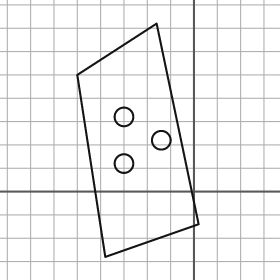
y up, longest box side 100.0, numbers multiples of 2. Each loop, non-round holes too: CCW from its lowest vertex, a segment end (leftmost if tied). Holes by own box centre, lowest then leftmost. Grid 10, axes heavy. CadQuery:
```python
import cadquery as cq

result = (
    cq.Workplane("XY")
    .moveTo(-38.0, -28.0)
    .lineTo(2.0, -14.0)
    .lineTo(-16.0, 72.0)
    .lineTo(-50.0, 50.0)
    .close()
    .moveTo(-30.0, 12.0)
    .circle(4.0)
    .moveTo(-14.0, 22.0)
    .circle(4.0)
    .moveTo(-30.0, 32.0)
    .circle(4.0)
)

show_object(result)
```